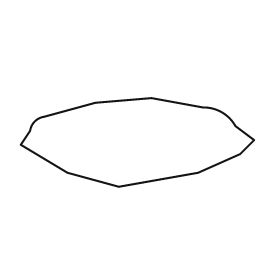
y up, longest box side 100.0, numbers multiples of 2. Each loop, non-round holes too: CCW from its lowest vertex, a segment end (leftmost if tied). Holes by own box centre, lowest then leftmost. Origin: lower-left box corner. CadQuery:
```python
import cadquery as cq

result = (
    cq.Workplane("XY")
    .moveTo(42.0, 0.0)
    .lineTo(76.0, 6.0)
    .lineTo(94.0, 14.0)
    .lineTo(100.0, 20.0)
    .lineTo(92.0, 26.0)
    .threePointArc((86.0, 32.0), (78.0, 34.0))
    .lineTo(56.0, 38.0)
    .lineTo(32.0, 36.0)
    .lineTo(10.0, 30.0)
    .threePointArc((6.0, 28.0), (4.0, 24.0))
    .lineTo(0.0, 18.0)
    .lineTo(20.0, 6.0)
    .close()
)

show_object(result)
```